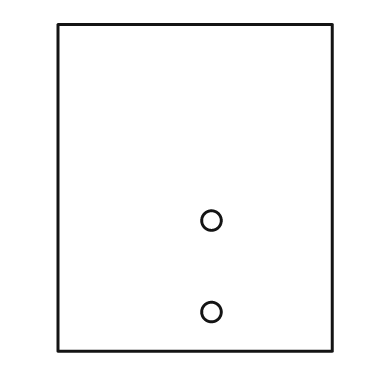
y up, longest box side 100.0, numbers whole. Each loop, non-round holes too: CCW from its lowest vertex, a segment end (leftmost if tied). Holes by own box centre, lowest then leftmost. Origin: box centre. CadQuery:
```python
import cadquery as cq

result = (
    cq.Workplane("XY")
    .moveTo(-42.0, -50.0)
    .lineTo(42.0, -50.0)
    .lineTo(42.0, 50.0)
    .lineTo(-42.0, 50.0)
    .close()
    .moveTo(5.0, -38.0)
    .circle(3.0)
    .moveTo(5.0, -10.0)
    .circle(3.0)
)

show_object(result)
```